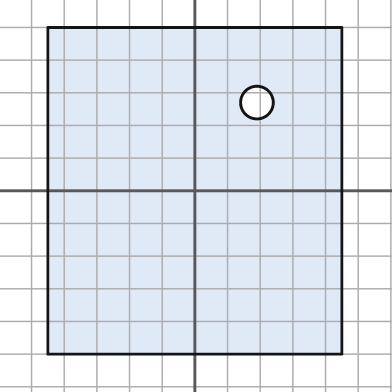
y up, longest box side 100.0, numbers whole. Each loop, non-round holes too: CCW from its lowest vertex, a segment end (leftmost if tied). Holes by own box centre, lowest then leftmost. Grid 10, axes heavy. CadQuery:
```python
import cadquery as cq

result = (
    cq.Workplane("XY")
    .moveTo(-45.0, -50.0)
    .lineTo(45.0, -50.0)
    .lineTo(45.0, 50.0)
    .lineTo(-45.0, 50.0)
    .close()
    .moveTo(19.0, 27.0)
    .circle(5.0)
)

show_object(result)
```